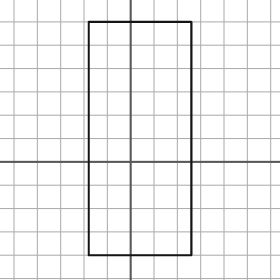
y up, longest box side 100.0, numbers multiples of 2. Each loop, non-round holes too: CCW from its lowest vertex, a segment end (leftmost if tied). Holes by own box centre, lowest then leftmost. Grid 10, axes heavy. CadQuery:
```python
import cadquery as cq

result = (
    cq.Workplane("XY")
    .moveTo(-18.0, -40.0)
    .lineTo(26.0, -40.0)
    .lineTo(26.0, 60.0)
    .lineTo(-18.0, 60.0)
    .close()
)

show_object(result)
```